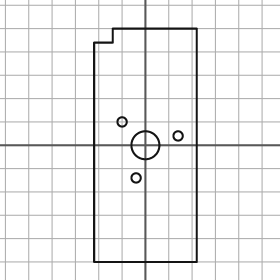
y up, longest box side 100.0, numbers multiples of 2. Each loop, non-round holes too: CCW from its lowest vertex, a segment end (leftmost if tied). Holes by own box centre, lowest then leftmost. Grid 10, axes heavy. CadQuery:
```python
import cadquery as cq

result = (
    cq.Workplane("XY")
    .moveTo(-22.0, -50.0)
    .lineTo(22.0, -50.0)
    .lineTo(22.0, 50.0)
    .lineTo(-14.0, 50.0)
    .lineTo(-14.0, 44.0)
    .lineTo(-22.0, 44.0)
    .close()
    .moveTo(-4.0, -14.0)
    .circle(2.0)
    .moveTo(0.0, 0.0)
    .circle(6.0)
    .moveTo(14.0, 4.0)
    .circle(2.0)
    .moveTo(-10.0, 10.0)
    .circle(2.0)
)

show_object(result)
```